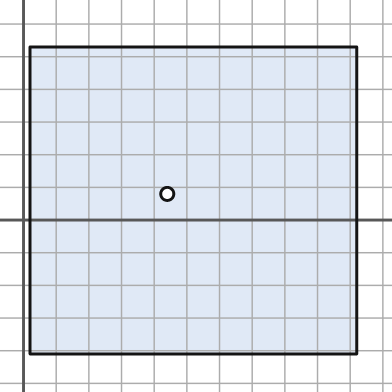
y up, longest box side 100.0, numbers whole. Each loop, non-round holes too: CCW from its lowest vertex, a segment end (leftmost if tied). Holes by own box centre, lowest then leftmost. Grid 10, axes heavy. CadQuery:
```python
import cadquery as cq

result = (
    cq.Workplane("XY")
    .moveTo(2.0, -41.0)
    .lineTo(102.0, -41.0)
    .lineTo(102.0, 53.0)
    .lineTo(2.0, 53.0)
    .close()
    .moveTo(44.0, 8.0)
    .circle(2.0)
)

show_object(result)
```